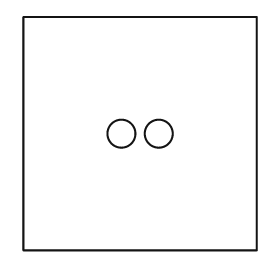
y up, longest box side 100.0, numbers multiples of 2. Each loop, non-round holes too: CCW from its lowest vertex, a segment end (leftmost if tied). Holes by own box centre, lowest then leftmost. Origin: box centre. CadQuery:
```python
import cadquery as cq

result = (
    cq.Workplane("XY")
    .moveTo(-50.0, -50.0)
    .lineTo(50.0, -50.0)
    .lineTo(50.0, 50.0)
    .lineTo(-50.0, 50.0)
    .close()
    .moveTo(-8.0, 0.0)
    .circle(6.0)
    .moveTo(8.0, 0.0)
    .circle(6.0)
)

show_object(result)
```